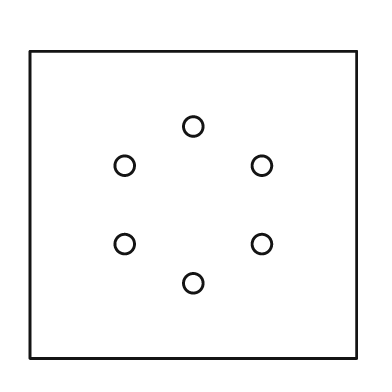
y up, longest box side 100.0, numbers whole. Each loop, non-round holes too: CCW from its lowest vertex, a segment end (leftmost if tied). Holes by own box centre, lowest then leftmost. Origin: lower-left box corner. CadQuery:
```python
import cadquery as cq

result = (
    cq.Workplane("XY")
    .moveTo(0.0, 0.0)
    .lineTo(100.0, 0.0)
    .lineTo(100.0, 94.0)
    .lineTo(0.0, 94.0)
    .close()
    .moveTo(50.0, 23.0)
    .circle(3.0)
    .moveTo(29.0, 35.0)
    .circle(3.0)
    .moveTo(71.0, 35.0)
    .circle(3.0)
    .moveTo(29.0, 59.0)
    .circle(3.0)
    .moveTo(71.0, 59.0)
    .circle(3.0)
    .moveTo(50.0, 71.0)
    .circle(3.0)
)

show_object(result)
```